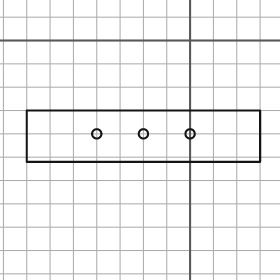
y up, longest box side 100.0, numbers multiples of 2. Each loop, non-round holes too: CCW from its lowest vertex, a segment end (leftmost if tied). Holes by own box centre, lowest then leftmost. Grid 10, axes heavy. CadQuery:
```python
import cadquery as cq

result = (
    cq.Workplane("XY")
    .moveTo(-70.0, -52.0)
    .lineTo(30.0, -52.0)
    .lineTo(30.0, -30.0)
    .lineTo(-70.0, -30.0)
    .close()
    .moveTo(-40.0, -40.0)
    .circle(2.0)
    .moveTo(-20.0, -40.0)
    .circle(2.0)
    .moveTo(0.0, -40.0)
    .circle(2.0)
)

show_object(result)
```